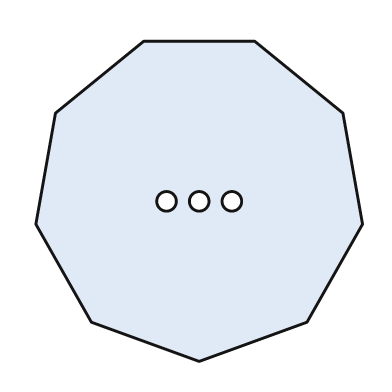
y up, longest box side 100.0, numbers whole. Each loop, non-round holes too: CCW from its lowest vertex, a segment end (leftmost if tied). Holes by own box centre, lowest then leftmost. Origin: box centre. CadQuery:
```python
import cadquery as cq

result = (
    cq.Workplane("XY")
    .moveTo(0.0, -49.0)
    .lineTo(33.0, -37.0)
    .lineTo(50.0, -7.0)
    .lineTo(44.0, 27.0)
    .lineTo(17.0, 49.0)
    .lineTo(-17.0, 49.0)
    .lineTo(-44.0, 27.0)
    .lineTo(-50.0, -7.0)
    .lineTo(-33.0, -37.0)
    .close()
    .moveTo(-10.0, 0.0)
    .circle(3.0)
    .moveTo(0.0, 0.0)
    .circle(3.0)
    .moveTo(10.0, 0.0)
    .circle(3.0)
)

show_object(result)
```